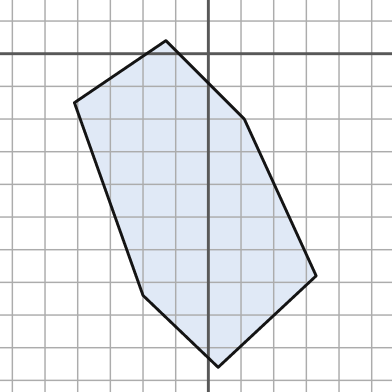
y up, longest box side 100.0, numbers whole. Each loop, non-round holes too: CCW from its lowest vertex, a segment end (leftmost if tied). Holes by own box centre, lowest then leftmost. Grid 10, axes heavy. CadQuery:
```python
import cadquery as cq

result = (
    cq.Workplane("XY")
    .moveTo(3.0, -96.0)
    .lineTo(33.0, -68.0)
    .lineTo(11.0, -20.0)
    .lineTo(-13.0, 4.0)
    .lineTo(-41.0, -15.0)
    .lineTo(-20.0, -74.0)
    .close()
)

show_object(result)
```